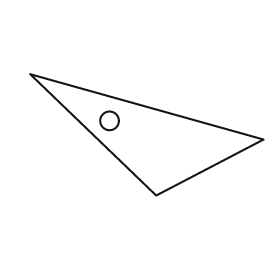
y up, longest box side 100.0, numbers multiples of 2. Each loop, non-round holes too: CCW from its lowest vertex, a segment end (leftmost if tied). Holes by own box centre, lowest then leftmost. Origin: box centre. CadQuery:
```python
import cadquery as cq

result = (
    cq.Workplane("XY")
    .moveTo(4.0, -26.0)
    .lineTo(50.0, -2.0)
    .lineTo(-50.0, 26.0)
    .close()
    .moveTo(-16.0, 6.0)
    .circle(4.0)
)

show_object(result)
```